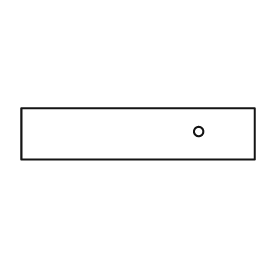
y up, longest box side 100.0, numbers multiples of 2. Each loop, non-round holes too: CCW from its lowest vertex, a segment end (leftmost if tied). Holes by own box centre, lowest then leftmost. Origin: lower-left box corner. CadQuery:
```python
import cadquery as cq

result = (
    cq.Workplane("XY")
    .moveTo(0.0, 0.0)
    .lineTo(100.0, 0.0)
    .lineTo(100.0, 22.0)
    .lineTo(0.0, 22.0)
    .close()
    .moveTo(76.0, 12.0)
    .circle(2.0)
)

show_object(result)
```